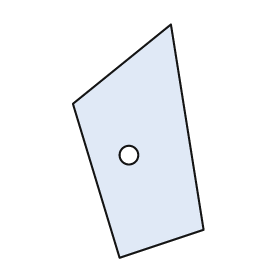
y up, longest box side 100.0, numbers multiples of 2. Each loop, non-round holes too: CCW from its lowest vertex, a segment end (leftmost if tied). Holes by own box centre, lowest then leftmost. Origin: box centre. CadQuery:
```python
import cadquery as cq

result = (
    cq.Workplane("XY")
    .moveTo(-8.0, -50.0)
    .lineTo(28.0, -38.0)
    .lineTo(14.0, 50.0)
    .lineTo(-28.0, 16.0)
    .close()
    .moveTo(-4.0, -6.0)
    .circle(4.0)
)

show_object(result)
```